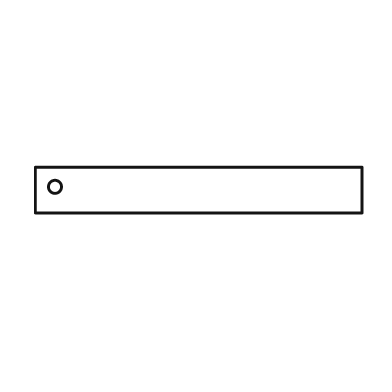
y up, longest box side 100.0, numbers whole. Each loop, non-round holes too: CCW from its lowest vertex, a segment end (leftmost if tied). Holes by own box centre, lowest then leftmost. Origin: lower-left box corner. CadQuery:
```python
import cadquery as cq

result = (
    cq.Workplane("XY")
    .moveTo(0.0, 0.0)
    .lineTo(100.0, 0.0)
    .lineTo(100.0, 14.0)
    .lineTo(0.0, 14.0)
    .close()
    .moveTo(6.0, 8.0)
    .circle(2.0)
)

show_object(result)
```